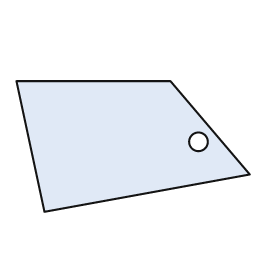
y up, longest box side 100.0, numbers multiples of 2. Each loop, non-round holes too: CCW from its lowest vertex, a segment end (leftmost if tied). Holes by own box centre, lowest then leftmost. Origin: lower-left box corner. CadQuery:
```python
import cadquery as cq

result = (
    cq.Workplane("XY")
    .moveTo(12.0, 0.0)
    .lineTo(100.0, 16.0)
    .lineTo(66.0, 56.0)
    .lineTo(0.0, 56.0)
    .close()
    .moveTo(78.0, 30.0)
    .circle(4.0)
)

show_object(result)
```